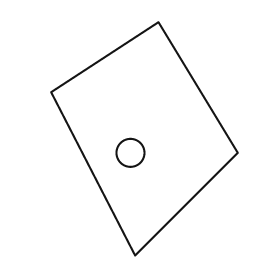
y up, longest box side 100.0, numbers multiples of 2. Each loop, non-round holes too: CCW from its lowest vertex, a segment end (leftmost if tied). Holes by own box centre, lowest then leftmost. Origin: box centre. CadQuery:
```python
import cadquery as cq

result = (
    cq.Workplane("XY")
    .moveTo(-4.0, -50.0)
    .lineTo(40.0, -6.0)
    .lineTo(6.0, 50.0)
    .lineTo(-40.0, 20.0)
    .close()
    .moveTo(-6.0, -6.0)
    .circle(6.0)
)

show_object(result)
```